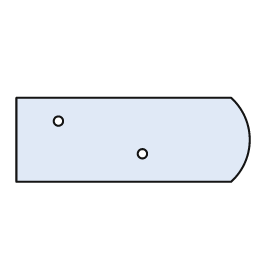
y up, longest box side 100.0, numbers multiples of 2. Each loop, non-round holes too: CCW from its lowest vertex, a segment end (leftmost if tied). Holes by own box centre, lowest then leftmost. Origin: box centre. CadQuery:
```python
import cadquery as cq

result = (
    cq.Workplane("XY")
    .moveTo(-50.0, -18.0)
    .lineTo(42.0, -18.0)
    .threePointArc((50.0, 0.0), (42.0, 18.0))
    .lineTo(-50.0, 18.0)
    .close()
    .moveTo(4.0, -6.0)
    .circle(2.0)
    .moveTo(-32.0, 8.0)
    .circle(2.0)
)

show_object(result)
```